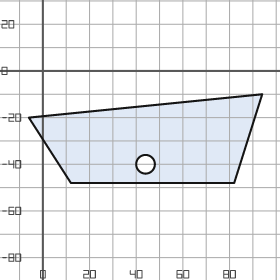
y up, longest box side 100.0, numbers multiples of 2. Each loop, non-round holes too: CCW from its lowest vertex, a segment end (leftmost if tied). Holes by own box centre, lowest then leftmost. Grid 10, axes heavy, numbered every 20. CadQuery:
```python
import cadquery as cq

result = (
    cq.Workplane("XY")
    .moveTo(12.0, -48.0)
    .lineTo(82.0, -48.0)
    .lineTo(94.0, -10.0)
    .lineTo(-6.0, -20.0)
    .close()
    .moveTo(44.0, -40.0)
    .circle(4.0)
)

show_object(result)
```